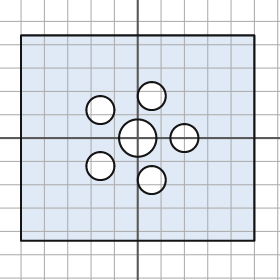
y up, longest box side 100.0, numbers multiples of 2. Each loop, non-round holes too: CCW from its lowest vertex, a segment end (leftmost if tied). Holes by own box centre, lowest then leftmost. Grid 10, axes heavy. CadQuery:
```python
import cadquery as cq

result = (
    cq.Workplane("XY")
    .moveTo(-50.0, -44.0)
    .lineTo(50.0, -44.0)
    .lineTo(50.0, 44.0)
    .lineTo(-50.0, 44.0)
    .close()
    .moveTo(6.0, -18.0)
    .circle(6.0)
    .moveTo(-16.0, -12.0)
    .circle(6.0)
    .moveTo(0.0, 0.0)
    .circle(8.0)
    .moveTo(20.0, 0.0)
    .circle(6.0)
    .moveTo(-16.0, 12.0)
    .circle(6.0)
    .moveTo(6.0, 18.0)
    .circle(6.0)
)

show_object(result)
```